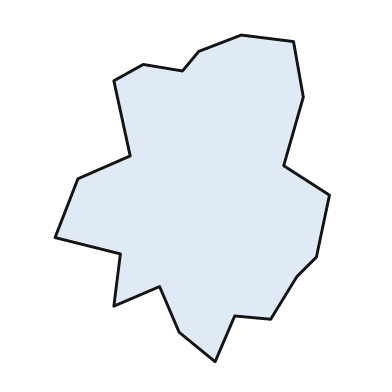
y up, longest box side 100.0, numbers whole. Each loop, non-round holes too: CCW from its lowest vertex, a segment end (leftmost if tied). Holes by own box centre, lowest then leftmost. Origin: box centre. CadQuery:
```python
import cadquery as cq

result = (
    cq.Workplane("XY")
    .moveTo(7.0, -50.0)
    .lineTo(13.0, -36.0)
    .lineTo(24.0, -37.0)
    .lineTo(32.0, -24.0)
    .lineTo(38.0, -18.0)
    .lineTo(42.0, 1.0)
    .lineTo(28.0, 10.0)
    .lineTo(34.0, 31.0)
    .lineTo(31.0, 48.0)
    .lineTo(15.0, 50.0)
    .lineTo(2.0, 45.0)
    .lineTo(-3.0, 39.0)
    .lineTo(-15.0, 41.0)
    .lineTo(-24.0, 36.0)
    .lineTo(-19.0, 13.0)
    .lineTo(-35.0, 6.0)
    .lineTo(-42.0, -12.0)
    .lineTo(-22.0, -17.0)
    .lineTo(-24.0, -33.0)
    .lineTo(-10.0, -27.0)
    .lineTo(-4.0, -41.0)
    .close()
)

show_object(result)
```